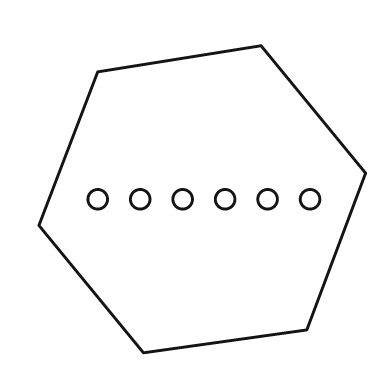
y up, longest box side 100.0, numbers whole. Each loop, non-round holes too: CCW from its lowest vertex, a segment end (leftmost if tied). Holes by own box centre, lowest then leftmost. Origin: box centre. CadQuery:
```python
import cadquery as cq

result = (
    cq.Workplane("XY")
    .moveTo(-18.0, -47.0)
    .lineTo(32.0, -40.0)
    .lineTo(50.0, 8.0)
    .lineTo(18.0, 47.0)
    .lineTo(-32.0, 39.0)
    .lineTo(-50.0, -8.0)
    .close()
    .moveTo(-32.0, 0.0)
    .circle(3.0)
    .moveTo(-19.0, 0.0)
    .circle(3.0)
    .moveTo(-6.0, 0.0)
    .circle(3.0)
    .moveTo(7.0, 0.0)
    .circle(3.0)
    .moveTo(20.0, 0.0)
    .circle(3.0)
    .moveTo(33.0, 0.0)
    .circle(3.0)
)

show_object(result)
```